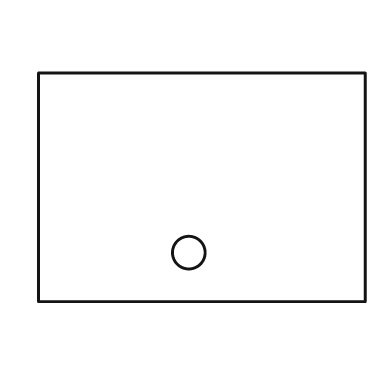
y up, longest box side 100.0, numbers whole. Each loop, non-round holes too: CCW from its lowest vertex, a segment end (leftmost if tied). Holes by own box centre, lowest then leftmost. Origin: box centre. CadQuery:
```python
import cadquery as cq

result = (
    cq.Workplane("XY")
    .moveTo(-50.0, -35.0)
    .lineTo(50.0, -35.0)
    .lineTo(50.0, 35.0)
    .lineTo(-50.0, 35.0)
    .close()
    .moveTo(-4.0, -20.0)
    .circle(5.0)
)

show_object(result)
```